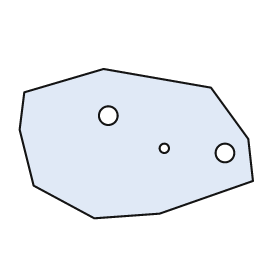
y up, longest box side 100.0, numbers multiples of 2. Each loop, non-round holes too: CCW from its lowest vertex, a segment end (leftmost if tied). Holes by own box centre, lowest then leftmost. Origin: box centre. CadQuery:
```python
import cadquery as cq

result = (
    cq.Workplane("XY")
    .moveTo(-18.0, -32.0)
    .lineTo(10.0, -30.0)
    .lineTo(50.0, -16.0)
    .lineTo(48.0, 2.0)
    .lineTo(32.0, 24.0)
    .lineTo(-14.0, 32.0)
    .lineTo(-48.0, 22.0)
    .lineTo(-50.0, 6.0)
    .lineTo(-44.0, -18.0)
    .close()
    .moveTo(38.0, -4.0)
    .circle(4.0)
    .moveTo(12.0, -2.0)
    .circle(2.0)
    .moveTo(-12.0, 12.0)
    .circle(4.0)
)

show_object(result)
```